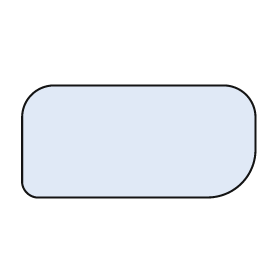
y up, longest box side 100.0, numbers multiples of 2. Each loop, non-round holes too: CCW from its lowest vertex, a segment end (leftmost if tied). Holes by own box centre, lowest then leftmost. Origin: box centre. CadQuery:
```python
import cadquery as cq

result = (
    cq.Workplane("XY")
    .moveTo(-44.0, -24.0)
    .lineTo(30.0, -24.0)
    .threePointArc((44.0, -18.0), (50.0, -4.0))
    .lineTo(50.0, 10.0)
    .threePointArc((46.0, 20.0), (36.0, 24.0))
    .lineTo(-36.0, 24.0)
    .threePointArc((-46.0, 20.0), (-50.0, 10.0))
    .lineTo(-50.0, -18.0)
    .threePointArc((-48.0, -22.0), (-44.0, -24.0))
    .close()
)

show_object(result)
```